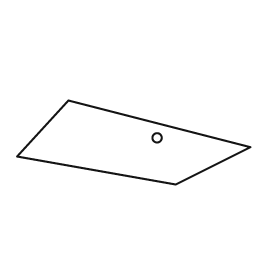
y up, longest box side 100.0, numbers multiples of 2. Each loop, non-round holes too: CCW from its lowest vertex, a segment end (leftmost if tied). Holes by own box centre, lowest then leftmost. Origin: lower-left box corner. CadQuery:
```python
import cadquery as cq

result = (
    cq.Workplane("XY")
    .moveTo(68.0, 0.0)
    .lineTo(100.0, 16.0)
    .lineTo(22.0, 36.0)
    .lineTo(0.0, 12.0)
    .close()
    .moveTo(60.0, 20.0)
    .circle(2.0)
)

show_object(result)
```